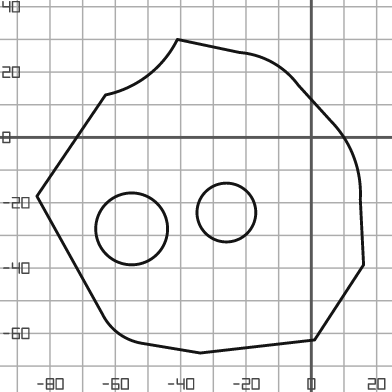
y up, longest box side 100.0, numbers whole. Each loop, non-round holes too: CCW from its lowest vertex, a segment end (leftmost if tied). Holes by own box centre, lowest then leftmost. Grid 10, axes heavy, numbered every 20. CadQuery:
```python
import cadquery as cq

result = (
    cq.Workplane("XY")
    .moveTo(-34.0, -66.0)
    .lineTo(1.0, -62.0)
    .lineTo(16.0, -39.0)
    .lineTo(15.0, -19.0)
    .threePointArc((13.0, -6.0), (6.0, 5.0))
    .lineTo(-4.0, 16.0)
    .threePointArc((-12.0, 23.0), (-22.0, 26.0))
    .lineTo(-41.0, 30.0)
    .threePointArc((-50.0, 19.0), (-63.0, 13.0))
    .lineTo(-84.0, -18.0)
    .lineTo(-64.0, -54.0)
    .threePointArc((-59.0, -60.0), (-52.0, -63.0))
    .close()
    .moveTo(-55.0, -28.0)
    .circle(11.0)
    .moveTo(-26.0, -23.0)
    .circle(9.0)
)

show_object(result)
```